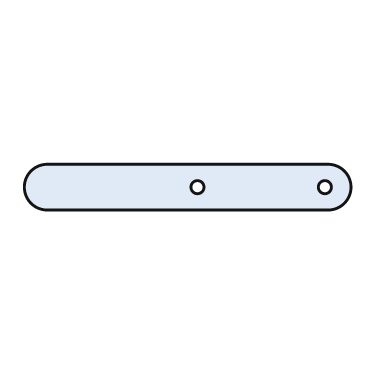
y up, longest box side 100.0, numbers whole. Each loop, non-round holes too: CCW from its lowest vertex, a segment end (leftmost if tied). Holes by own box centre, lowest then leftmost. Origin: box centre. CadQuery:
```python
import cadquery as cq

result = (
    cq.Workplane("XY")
    .moveTo(-43.0, -7.0)
    .lineTo(43.0, -7.0)
    .threePointArc((50.0, 0.0), (43.0, 7.0))
    .lineTo(-43.0, 7.0)
    .threePointArc((-50.0, 0.0), (-43.0, -7.0))
    .close()
    .moveTo(3.0, 0.0)
    .circle(2.0)
    .moveTo(42.0, 0.0)
    .circle(2.0)
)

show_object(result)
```